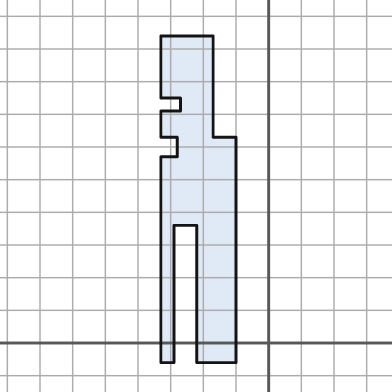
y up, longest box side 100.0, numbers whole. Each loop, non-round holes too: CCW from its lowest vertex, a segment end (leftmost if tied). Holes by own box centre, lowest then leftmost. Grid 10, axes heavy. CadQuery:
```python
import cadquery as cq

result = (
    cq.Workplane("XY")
    .moveTo(-33.0, -6.0)
    .lineTo(-29.0, -6.0)
    .lineTo(-29.0, 36.0)
    .lineTo(-22.0, 36.0)
    .lineTo(-22.0, -6.0)
    .lineTo(-10.0, -6.0)
    .lineTo(-10.0, 63.0)
    .lineTo(-17.0, 63.0)
    .lineTo(-17.0, 94.0)
    .lineTo(-33.0, 94.0)
    .lineTo(-33.0, 75.0)
    .lineTo(-27.0, 75.0)
    .lineTo(-27.0, 71.0)
    .lineTo(-33.0, 71.0)
    .lineTo(-33.0, 63.0)
    .lineTo(-28.0, 63.0)
    .lineTo(-28.0, 57.0)
    .lineTo(-33.0, 57.0)
    .close()
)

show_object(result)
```